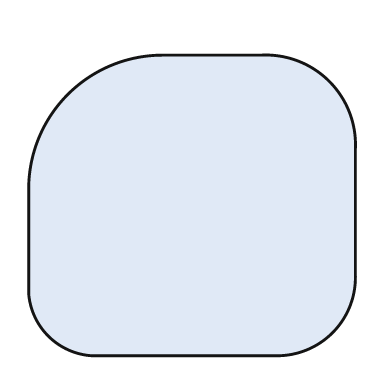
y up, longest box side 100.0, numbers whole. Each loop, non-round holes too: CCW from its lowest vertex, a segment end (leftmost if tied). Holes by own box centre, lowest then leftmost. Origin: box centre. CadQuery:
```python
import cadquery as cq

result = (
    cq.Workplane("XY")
    .moveTo(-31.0, -46.0)
    .lineTo(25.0, -46.0)
    .threePointArc((43.0, -39.0), (50.0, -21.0))
    .lineTo(50.0, 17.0)
    .threePointArc((42.0, 38.0), (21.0, 46.0))
    .lineTo(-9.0, 46.0)
    .threePointArc((-38.0, 34.0), (-50.0, 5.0))
    .lineTo(-50.0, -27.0)
    .threePointArc((-44.0, -40.0), (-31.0, -46.0))
    .close()
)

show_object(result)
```